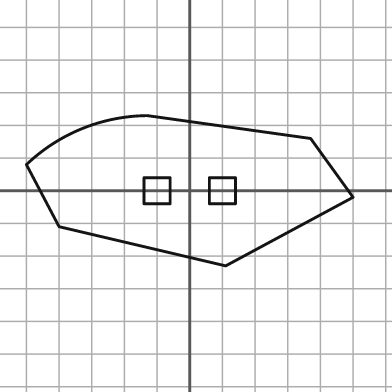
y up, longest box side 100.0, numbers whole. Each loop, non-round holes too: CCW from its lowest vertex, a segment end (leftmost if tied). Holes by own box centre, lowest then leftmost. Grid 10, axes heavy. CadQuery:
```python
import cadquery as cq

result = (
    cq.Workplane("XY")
    .moveTo(11.0, -23.0)
    .lineTo(50.0, -2.0)
    .lineTo(37.0, 16.0)
    .lineTo(-13.0, 23.0)
    .threePointArc((-33.0, 19.0), (-50.0, 8.0))
    .lineTo(-40.0, -11.0)
    .close()
    .moveTo(-14.0, -4.0)
    .lineTo(-6.0, -4.0)
    .lineTo(-6.0, 4.0)
    .lineTo(-14.0, 4.0)
    .close()
    .moveTo(6.0, -4.0)
    .lineTo(14.0, -4.0)
    .lineTo(14.0, 4.0)
    .lineTo(6.0, 4.0)
    .close()
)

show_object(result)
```